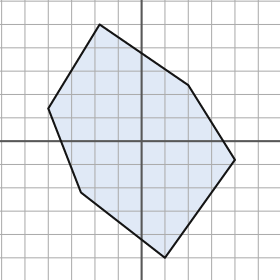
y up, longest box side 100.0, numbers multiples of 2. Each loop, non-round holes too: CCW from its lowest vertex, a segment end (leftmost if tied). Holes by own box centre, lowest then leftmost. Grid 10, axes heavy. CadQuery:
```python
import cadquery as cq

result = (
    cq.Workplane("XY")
    .moveTo(10.0, -50.0)
    .lineTo(40.0, -8.0)
    .lineTo(20.0, 24.0)
    .lineTo(-18.0, 50.0)
    .lineTo(-40.0, 14.0)
    .lineTo(-26.0, -22.0)
    .close()
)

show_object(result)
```